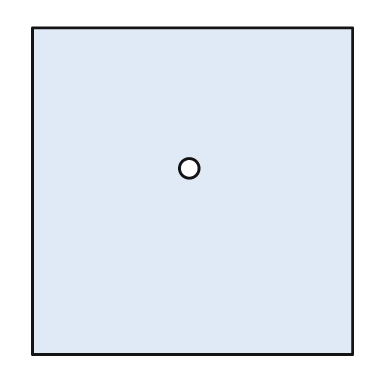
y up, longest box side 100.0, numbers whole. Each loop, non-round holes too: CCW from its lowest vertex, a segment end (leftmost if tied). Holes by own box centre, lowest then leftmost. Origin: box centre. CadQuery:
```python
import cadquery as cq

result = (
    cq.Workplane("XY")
    .moveTo(-49.0, -50.0)
    .lineTo(49.0, -50.0)
    .lineTo(49.0, 50.0)
    .lineTo(-49.0, 50.0)
    .close()
    .moveTo(-1.0, 7.0)
    .circle(3.0)
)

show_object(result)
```